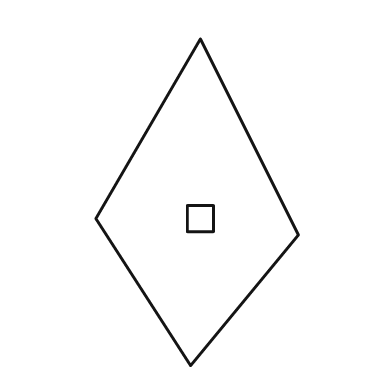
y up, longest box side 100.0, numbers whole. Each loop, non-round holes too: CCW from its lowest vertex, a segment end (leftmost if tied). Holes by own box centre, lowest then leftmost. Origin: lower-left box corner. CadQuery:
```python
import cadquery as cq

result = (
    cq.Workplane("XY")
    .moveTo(29.0, 0.0)
    .lineTo(62.0, 40.0)
    .lineTo(32.0, 100.0)
    .lineTo(0.0, 45.0)
    .close()
    .moveTo(28.0, 41.0)
    .lineTo(36.0, 41.0)
    .lineTo(36.0, 49.0)
    .lineTo(28.0, 49.0)
    .close()
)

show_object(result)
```